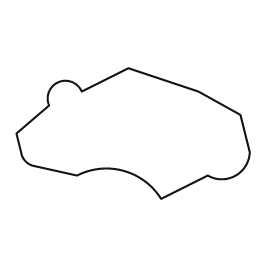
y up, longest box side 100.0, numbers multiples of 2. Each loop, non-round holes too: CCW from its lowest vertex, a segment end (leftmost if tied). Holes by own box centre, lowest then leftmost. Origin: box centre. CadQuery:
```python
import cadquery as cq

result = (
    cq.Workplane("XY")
    .moveTo(12.0, -28.0)
    .lineTo(32.0, -18.0)
    .threePointArc((44.0, -18.0), (50.0, -8.0))
    .lineTo(46.0, 8.0)
    .lineTo(28.0, 18.0)
    .lineTo(-2.0, 28.0)
    .lineTo(-22.0, 18.0)
    .threePointArc((-32.0, 22.0), (-36.0, 12.0))
    .lineTo(-50.0, 0.0)
    .lineTo(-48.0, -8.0)
    .threePointArc((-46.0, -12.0), (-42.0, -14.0))
    .lineTo(-24.0, -18.0)
    .threePointArc((-4.0, -16.0), (12.0, -28.0))
    .close()
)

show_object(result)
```